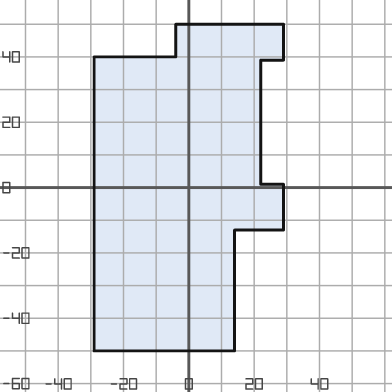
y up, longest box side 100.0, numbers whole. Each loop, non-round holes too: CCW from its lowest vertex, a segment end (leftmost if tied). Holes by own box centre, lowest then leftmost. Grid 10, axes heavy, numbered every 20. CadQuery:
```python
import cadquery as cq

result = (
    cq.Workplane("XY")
    .moveTo(-29.0, -50.0)
    .lineTo(14.0, -50.0)
    .lineTo(14.0, -13.0)
    .lineTo(29.0, -13.0)
    .lineTo(29.0, 1.0)
    .lineTo(22.0, 1.0)
    .lineTo(22.0, 39.0)
    .lineTo(29.0, 39.0)
    .lineTo(29.0, 50.0)
    .lineTo(-4.0, 50.0)
    .lineTo(-4.0, 40.0)
    .lineTo(-29.0, 40.0)
    .close()
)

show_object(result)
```